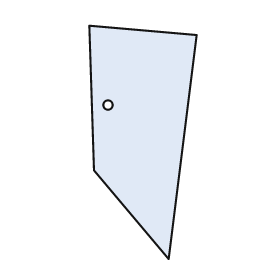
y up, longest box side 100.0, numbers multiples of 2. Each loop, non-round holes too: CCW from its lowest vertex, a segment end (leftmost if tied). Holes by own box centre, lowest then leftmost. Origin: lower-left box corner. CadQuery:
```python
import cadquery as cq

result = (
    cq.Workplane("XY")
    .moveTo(34.0, 0.0)
    .lineTo(46.0, 96.0)
    .lineTo(0.0, 100.0)
    .lineTo(2.0, 38.0)
    .close()
    .moveTo(8.0, 66.0)
    .circle(2.0)
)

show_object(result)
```